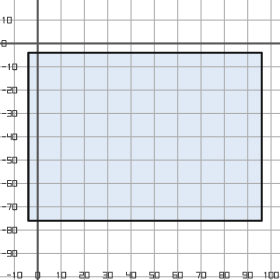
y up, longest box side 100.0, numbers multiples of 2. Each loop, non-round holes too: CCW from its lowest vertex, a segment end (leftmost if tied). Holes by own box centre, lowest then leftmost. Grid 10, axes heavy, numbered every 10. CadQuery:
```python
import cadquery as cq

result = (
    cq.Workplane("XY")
    .moveTo(-4.0, -76.0)
    .lineTo(96.0, -76.0)
    .lineTo(96.0, -4.0)
    .lineTo(-4.0, -4.0)
    .close()
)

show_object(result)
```